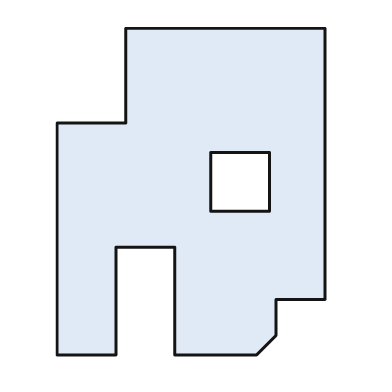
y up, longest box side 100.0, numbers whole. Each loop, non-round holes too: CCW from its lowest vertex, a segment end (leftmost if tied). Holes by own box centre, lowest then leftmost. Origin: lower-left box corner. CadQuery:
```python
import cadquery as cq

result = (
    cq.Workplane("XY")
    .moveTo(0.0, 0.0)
    .lineTo(18.0, 0.0)
    .lineTo(18.0, 33.0)
    .lineTo(36.0, 33.0)
    .lineTo(36.0, 0.0)
    .lineTo(61.0, 0.0)
    .lineTo(67.0, 6.0)
    .lineTo(67.0, 17.0)
    .lineTo(82.0, 17.0)
    .lineTo(82.0, 100.0)
    .lineTo(21.0, 100.0)
    .lineTo(21.0, 71.0)
    .lineTo(0.0, 71.0)
    .close()
    .moveTo(47.0, 44.0)
    .lineTo(65.0, 44.0)
    .lineTo(65.0, 62.0)
    .lineTo(47.0, 62.0)
    .close()
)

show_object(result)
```